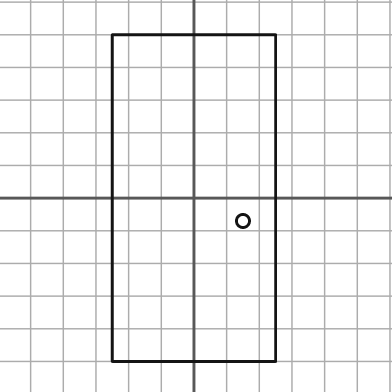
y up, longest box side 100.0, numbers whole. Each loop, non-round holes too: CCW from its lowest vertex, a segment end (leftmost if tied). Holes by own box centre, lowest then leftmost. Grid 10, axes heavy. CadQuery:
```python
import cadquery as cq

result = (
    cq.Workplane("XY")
    .moveTo(-25.0, -50.0)
    .lineTo(25.0, -50.0)
    .lineTo(25.0, 50.0)
    .lineTo(-25.0, 50.0)
    .close()
    .moveTo(15.0, -7.0)
    .circle(2.0)
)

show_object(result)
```